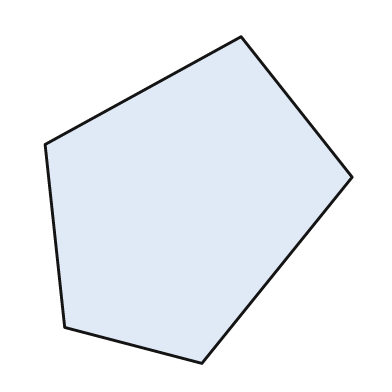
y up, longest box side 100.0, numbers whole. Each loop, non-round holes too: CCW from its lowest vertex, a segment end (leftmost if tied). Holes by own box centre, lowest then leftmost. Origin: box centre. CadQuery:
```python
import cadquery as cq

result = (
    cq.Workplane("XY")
    .moveTo(1.0, -50.0)
    .lineTo(47.0, 7.0)
    .lineTo(13.0, 50.0)
    .lineTo(-47.0, 17.0)
    .lineTo(-41.0, -39.0)
    .close()
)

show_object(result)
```